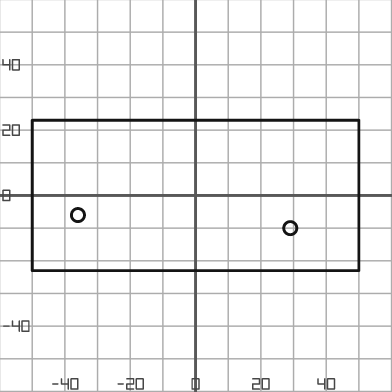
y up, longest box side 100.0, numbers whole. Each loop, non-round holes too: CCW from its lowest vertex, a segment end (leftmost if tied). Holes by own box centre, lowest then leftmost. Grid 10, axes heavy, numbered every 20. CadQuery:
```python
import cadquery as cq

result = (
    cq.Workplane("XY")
    .moveTo(-50.0, -23.0)
    .lineTo(50.0, -23.0)
    .lineTo(50.0, 23.0)
    .lineTo(-50.0, 23.0)
    .close()
    .moveTo(29.0, -10.0)
    .circle(2.0)
    .moveTo(-36.0, -6.0)
    .circle(2.0)
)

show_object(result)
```